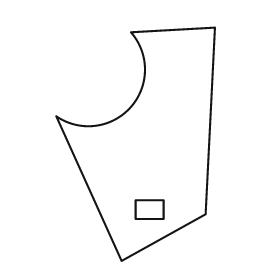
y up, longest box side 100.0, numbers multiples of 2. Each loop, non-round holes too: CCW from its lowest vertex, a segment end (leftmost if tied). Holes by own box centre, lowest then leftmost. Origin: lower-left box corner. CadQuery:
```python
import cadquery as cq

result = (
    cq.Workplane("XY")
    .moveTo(28.0, 0.0)
    .lineTo(64.0, 20.0)
    .lineTo(68.0, 100.0)
    .lineTo(32.0, 98.0)
    .threePointArc((32.0, 66.0), (0.0, 62.0))
    .close()
    .moveTo(34.0, 18.0)
    .lineTo(46.0, 18.0)
    .lineTo(46.0, 26.0)
    .lineTo(34.0, 26.0)
    .close()
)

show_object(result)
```